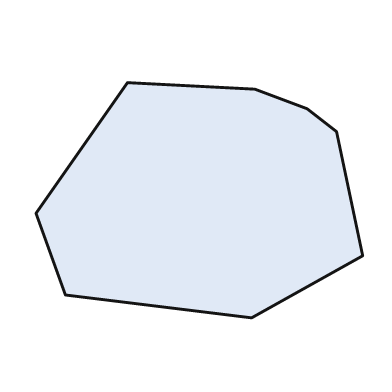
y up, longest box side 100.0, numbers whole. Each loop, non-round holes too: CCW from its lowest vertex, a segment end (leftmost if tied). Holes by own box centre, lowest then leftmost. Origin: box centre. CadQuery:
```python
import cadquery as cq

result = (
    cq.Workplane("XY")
    .moveTo(16.0, -36.0)
    .lineTo(50.0, -17.0)
    .lineTo(42.0, 21.0)
    .lineTo(33.0, 28.0)
    .lineTo(17.0, 34.0)
    .lineTo(-22.0, 36.0)
    .lineTo(-50.0, -4.0)
    .lineTo(-41.0, -29.0)
    .close()
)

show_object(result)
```